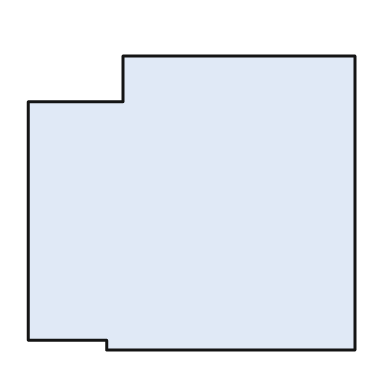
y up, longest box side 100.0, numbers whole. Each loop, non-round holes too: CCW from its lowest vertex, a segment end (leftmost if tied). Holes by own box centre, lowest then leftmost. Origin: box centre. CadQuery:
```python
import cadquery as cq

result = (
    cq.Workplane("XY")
    .moveTo(-26.0, -45.0)
    .lineTo(50.0, -45.0)
    .lineTo(50.0, 45.0)
    .lineTo(-21.0, 45.0)
    .lineTo(-21.0, 31.0)
    .lineTo(-50.0, 31.0)
    .lineTo(-50.0, -42.0)
    .lineTo(-26.0, -42.0)
    .close()
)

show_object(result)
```